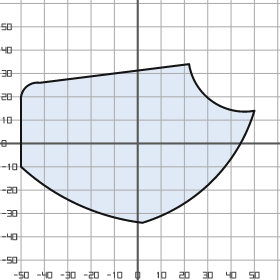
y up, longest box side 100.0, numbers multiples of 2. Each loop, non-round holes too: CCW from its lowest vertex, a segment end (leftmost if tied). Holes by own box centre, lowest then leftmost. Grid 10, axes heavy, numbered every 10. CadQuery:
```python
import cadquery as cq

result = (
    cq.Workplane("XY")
    .moveTo(2.0, -34.0)
    .threePointArc((32.0, -16.0), (50.0, 14.0))
    .threePointArc((32.0, 18.0), (22.0, 34.0))
    .lineTo(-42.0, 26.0)
    .threePointArc((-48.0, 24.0), (-50.0, 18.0))
    .lineTo(-50.0, -10.0)
    .threePointArc((-26.0, -26.0), (2.0, -34.0))
    .close()
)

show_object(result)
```